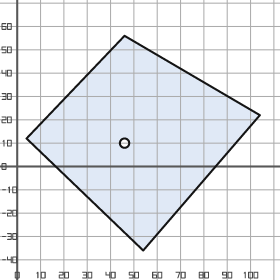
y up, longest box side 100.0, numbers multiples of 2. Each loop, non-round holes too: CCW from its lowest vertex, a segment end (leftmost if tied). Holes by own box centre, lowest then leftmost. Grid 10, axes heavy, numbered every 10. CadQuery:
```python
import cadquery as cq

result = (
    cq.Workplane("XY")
    .moveTo(54.0, -36.0)
    .lineTo(104.0, 22.0)
    .lineTo(46.0, 56.0)
    .lineTo(4.0, 12.0)
    .close()
    .moveTo(46.0, 10.0)
    .circle(2.0)
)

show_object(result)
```